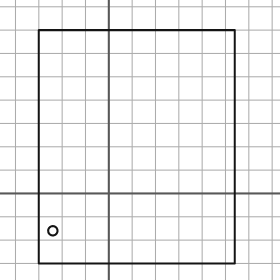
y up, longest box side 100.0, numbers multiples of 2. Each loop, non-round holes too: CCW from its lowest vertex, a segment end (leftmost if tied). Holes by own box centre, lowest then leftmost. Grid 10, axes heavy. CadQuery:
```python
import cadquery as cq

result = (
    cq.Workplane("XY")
    .moveTo(-30.0, -30.0)
    .lineTo(54.0, -30.0)
    .lineTo(54.0, 70.0)
    .lineTo(-30.0, 70.0)
    .close()
    .moveTo(-24.0, -16.0)
    .circle(2.0)
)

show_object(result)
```